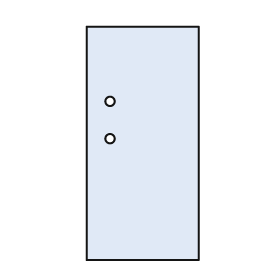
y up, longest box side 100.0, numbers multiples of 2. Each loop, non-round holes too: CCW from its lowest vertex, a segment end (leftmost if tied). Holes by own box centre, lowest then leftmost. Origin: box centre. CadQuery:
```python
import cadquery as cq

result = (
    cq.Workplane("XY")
    .moveTo(-24.0, -50.0)
    .lineTo(24.0, -50.0)
    .lineTo(24.0, 50.0)
    .lineTo(-24.0, 50.0)
    .close()
    .moveTo(-14.0, 2.0)
    .circle(2.0)
    .moveTo(-14.0, 18.0)
    .circle(2.0)
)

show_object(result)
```